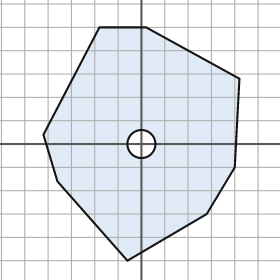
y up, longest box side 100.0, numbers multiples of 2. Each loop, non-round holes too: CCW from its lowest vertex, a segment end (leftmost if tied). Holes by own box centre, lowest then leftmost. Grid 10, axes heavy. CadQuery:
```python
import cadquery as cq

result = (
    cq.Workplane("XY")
    .moveTo(-6.0, -50.0)
    .lineTo(28.0, -30.0)
    .lineTo(40.0, -10.0)
    .lineTo(42.0, 28.0)
    .lineTo(2.0, 50.0)
    .lineTo(-18.0, 50.0)
    .lineTo(-42.0, 4.0)
    .lineTo(-36.0, -16.0)
    .close()
    .moveTo(0.0, 0.0)
    .circle(6.0)
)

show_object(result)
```